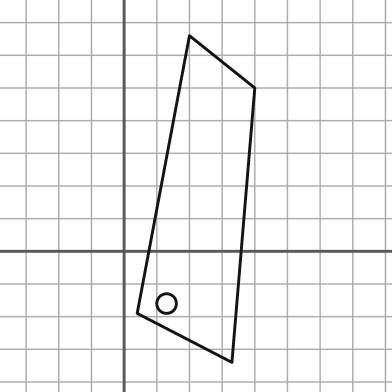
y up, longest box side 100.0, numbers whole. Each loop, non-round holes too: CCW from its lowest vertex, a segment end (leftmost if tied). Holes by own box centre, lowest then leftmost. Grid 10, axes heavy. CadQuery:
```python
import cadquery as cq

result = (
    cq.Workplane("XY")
    .moveTo(33.0, -34.0)
    .lineTo(40.0, 50.0)
    .lineTo(20.0, 66.0)
    .lineTo(4.0, -19.0)
    .close()
    .moveTo(13.0, -16.0)
    .circle(3.0)
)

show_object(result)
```